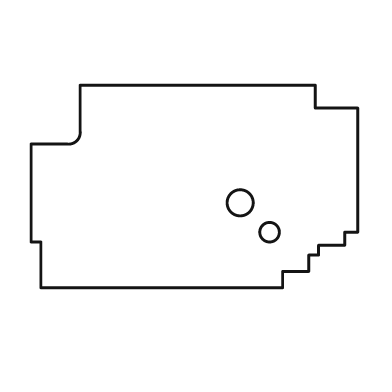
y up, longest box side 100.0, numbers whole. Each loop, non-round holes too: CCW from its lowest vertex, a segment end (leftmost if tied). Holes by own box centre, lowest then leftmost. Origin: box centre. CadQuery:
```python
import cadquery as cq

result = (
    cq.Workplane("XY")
    .moveTo(-47.0, -31.0)
    .lineTo(27.0, -31.0)
    .lineTo(27.0, -26.0)
    .lineTo(35.0, -26.0)
    .lineTo(35.0, -21.0)
    .lineTo(38.0, -21.0)
    .lineTo(38.0, -18.0)
    .lineTo(46.0, -18.0)
    .lineTo(46.0, -14.0)
    .lineTo(50.0, -14.0)
    .lineTo(50.0, 24.0)
    .lineTo(37.0, 24.0)
    .lineTo(37.0, 31.0)
    .lineTo(-35.0, 31.0)
    .lineTo(-35.0, 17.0)
    .threePointArc((-36.0, 14.0), (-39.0, 13.0))
    .lineTo(-50.0, 13.0)
    .lineTo(-50.0, -17.0)
    .lineTo(-47.0, -17.0)
    .close()
    .moveTo(23.0, -14.0)
    .circle(3.0)
    .moveTo(14.0, -5.0)
    .circle(4.0)
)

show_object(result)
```